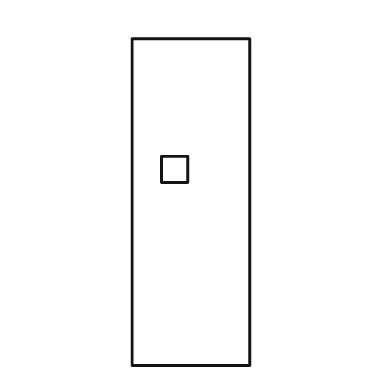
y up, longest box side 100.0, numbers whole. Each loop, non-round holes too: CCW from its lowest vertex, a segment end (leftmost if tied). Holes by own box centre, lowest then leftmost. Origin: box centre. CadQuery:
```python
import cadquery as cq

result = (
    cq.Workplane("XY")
    .moveTo(-18.0, -50.0)
    .lineTo(18.0, -50.0)
    .lineTo(18.0, 50.0)
    .lineTo(-18.0, 50.0)
    .close()
    .moveTo(-9.0, 6.0)
    .lineTo(-1.0, 6.0)
    .lineTo(-1.0, 14.0)
    .lineTo(-9.0, 14.0)
    .close()
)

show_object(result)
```